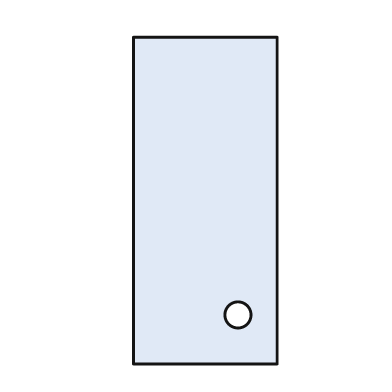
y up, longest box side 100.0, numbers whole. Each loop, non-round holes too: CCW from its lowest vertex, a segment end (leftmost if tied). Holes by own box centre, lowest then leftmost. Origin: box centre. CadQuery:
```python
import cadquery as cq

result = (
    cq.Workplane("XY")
    .moveTo(-22.0, -50.0)
    .lineTo(22.0, -50.0)
    .lineTo(22.0, 50.0)
    .lineTo(-22.0, 50.0)
    .close()
    .moveTo(10.0, -35.0)
    .circle(4.0)
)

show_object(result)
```